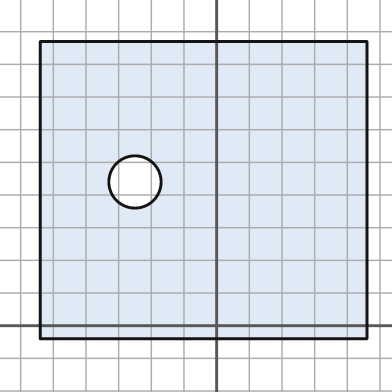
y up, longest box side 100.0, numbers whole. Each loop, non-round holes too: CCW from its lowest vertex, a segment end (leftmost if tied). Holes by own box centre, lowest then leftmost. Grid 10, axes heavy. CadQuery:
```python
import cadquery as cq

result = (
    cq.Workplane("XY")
    .moveTo(-54.0, -4.0)
    .lineTo(46.0, -4.0)
    .lineTo(46.0, 87.0)
    .lineTo(-54.0, 87.0)
    .close()
    .moveTo(-25.0, 44.0)
    .circle(8.0)
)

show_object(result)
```